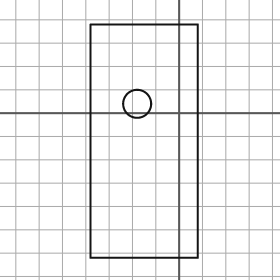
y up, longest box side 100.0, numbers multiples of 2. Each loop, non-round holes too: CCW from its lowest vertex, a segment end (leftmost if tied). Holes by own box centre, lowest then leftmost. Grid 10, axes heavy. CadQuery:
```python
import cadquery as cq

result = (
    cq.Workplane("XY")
    .moveTo(-38.0, -62.0)
    .lineTo(8.0, -62.0)
    .lineTo(8.0, 38.0)
    .lineTo(-38.0, 38.0)
    .close()
    .moveTo(-18.0, 4.0)
    .circle(6.0)
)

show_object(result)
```